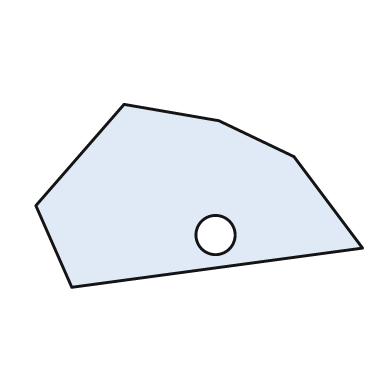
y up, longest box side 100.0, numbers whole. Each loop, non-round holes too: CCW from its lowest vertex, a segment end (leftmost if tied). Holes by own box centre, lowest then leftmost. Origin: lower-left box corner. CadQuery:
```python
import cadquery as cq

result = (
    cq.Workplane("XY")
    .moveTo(11.0, 0.0)
    .lineTo(100.0, 12.0)
    .lineTo(79.0, 40.0)
    .lineTo(56.0, 51.0)
    .lineTo(27.0, 56.0)
    .lineTo(0.0, 25.0)
    .close()
    .moveTo(55.0, 16.0)
    .circle(6.0)
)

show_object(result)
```